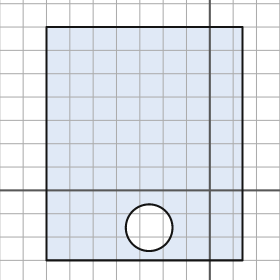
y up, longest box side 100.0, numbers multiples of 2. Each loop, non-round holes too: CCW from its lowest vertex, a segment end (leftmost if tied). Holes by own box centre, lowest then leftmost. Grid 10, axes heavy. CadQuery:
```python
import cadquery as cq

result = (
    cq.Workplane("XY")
    .moveTo(-70.0, -30.0)
    .lineTo(14.0, -30.0)
    .lineTo(14.0, 70.0)
    .lineTo(-70.0, 70.0)
    .close()
    .moveTo(-26.0, -16.0)
    .circle(10.0)
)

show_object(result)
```